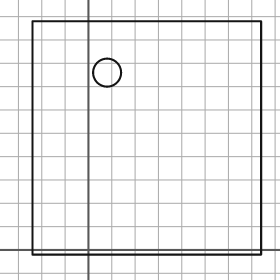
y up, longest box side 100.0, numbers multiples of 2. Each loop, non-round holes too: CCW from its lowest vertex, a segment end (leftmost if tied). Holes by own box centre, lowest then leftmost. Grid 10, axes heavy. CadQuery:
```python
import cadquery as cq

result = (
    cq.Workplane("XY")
    .moveTo(-24.0, -2.0)
    .lineTo(74.0, -2.0)
    .lineTo(74.0, 98.0)
    .lineTo(-24.0, 98.0)
    .close()
    .moveTo(8.0, 76.0)
    .circle(6.0)
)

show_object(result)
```